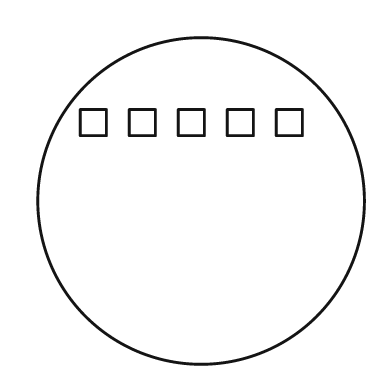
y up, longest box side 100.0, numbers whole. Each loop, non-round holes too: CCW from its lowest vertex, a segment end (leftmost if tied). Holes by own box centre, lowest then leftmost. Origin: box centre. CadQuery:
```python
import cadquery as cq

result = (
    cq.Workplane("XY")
    .moveTo(0.0, 0.0)
    .circle(50.0)
    .moveTo(-37.0, 20.0)
    .lineTo(-29.0, 20.0)
    .lineTo(-29.0, 28.0)
    .lineTo(-37.0, 28.0)
    .close()
    .moveTo(-22.0, 20.0)
    .lineTo(-14.0, 20.0)
    .lineTo(-14.0, 28.0)
    .lineTo(-22.0, 28.0)
    .close()
    .moveTo(-7.0, 20.0)
    .lineTo(1.0, 20.0)
    .lineTo(1.0, 28.0)
    .lineTo(-7.0, 28.0)
    .close()
    .moveTo(8.0, 20.0)
    .lineTo(16.0, 20.0)
    .lineTo(16.0, 28.0)
    .lineTo(8.0, 28.0)
    .close()
    .moveTo(23.0, 20.0)
    .lineTo(31.0, 20.0)
    .lineTo(31.0, 28.0)
    .lineTo(23.0, 28.0)
    .close()
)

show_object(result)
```